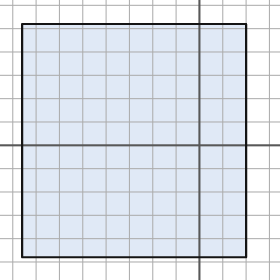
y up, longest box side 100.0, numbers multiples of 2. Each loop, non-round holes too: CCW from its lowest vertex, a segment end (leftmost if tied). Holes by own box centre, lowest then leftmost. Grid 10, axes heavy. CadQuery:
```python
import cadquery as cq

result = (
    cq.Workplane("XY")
    .moveTo(-76.0, -48.0)
    .lineTo(20.0, -48.0)
    .lineTo(20.0, 52.0)
    .lineTo(-76.0, 52.0)
    .close()
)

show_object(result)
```